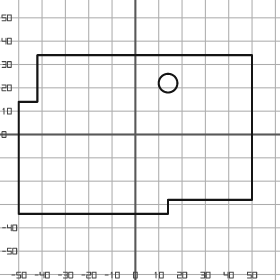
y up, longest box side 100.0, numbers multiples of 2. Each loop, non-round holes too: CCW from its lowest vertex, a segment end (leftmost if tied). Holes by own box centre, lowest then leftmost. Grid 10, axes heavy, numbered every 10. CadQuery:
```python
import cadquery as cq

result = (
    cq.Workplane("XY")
    .moveTo(-50.0, -34.0)
    .lineTo(14.0, -34.0)
    .lineTo(14.0, -28.0)
    .lineTo(50.0, -28.0)
    .lineTo(50.0, 34.0)
    .lineTo(-42.0, 34.0)
    .lineTo(-42.0, 14.0)
    .lineTo(-50.0, 14.0)
    .close()
    .moveTo(14.0, 22.0)
    .circle(4.0)
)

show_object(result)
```